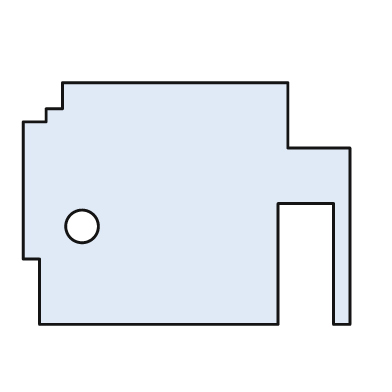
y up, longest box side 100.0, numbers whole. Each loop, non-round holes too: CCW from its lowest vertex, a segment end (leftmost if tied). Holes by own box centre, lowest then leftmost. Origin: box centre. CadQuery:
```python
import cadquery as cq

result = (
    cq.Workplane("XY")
    .moveTo(-45.0, -37.0)
    .lineTo(28.0, -37.0)
    .lineTo(28.0, 0.0)
    .lineTo(45.0, 0.0)
    .lineTo(45.0, -37.0)
    .lineTo(50.0, -37.0)
    .lineTo(50.0, 17.0)
    .lineTo(31.0, 17.0)
    .lineTo(31.0, 37.0)
    .lineTo(-38.0, 37.0)
    .lineTo(-38.0, 29.0)
    .lineTo(-43.0, 29.0)
    .lineTo(-43.0, 25.0)
    .lineTo(-50.0, 25.0)
    .lineTo(-50.0, -17.0)
    .lineTo(-45.0, -17.0)
    .close()
    .moveTo(-32.0, -7.0)
    .circle(5.0)
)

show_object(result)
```